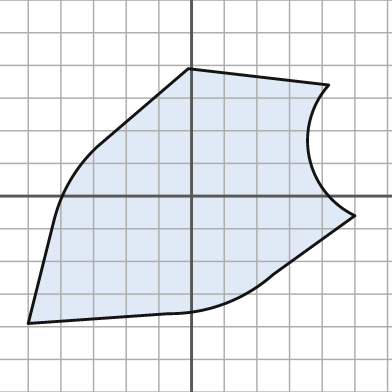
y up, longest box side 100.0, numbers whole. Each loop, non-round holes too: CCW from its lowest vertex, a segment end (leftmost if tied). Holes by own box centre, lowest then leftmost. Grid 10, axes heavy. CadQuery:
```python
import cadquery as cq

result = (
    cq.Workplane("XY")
    .moveTo(-50.0, -39.0)
    .lineTo(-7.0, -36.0)
    .threePointArc((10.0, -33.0), (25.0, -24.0))
    .lineTo(50.0, -6.0)
    .threePointArc((36.0, 12.0), (42.0, 34.0))
    .lineTo(-1.0, 39.0)
    .lineTo(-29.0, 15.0)
    .threePointArc((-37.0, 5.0), (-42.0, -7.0))
    .close()
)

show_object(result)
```